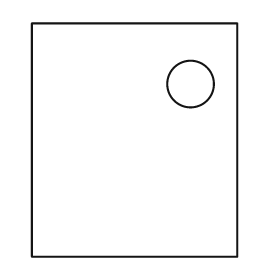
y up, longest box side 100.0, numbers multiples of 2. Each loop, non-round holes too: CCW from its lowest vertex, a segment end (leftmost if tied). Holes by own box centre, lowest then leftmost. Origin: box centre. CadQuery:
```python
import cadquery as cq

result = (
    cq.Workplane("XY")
    .moveTo(-44.0, -50.0)
    .lineTo(44.0, -50.0)
    .lineTo(44.0, 50.0)
    .lineTo(-44.0, 50.0)
    .close()
    .moveTo(24.0, 24.0)
    .circle(10.0)
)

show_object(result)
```